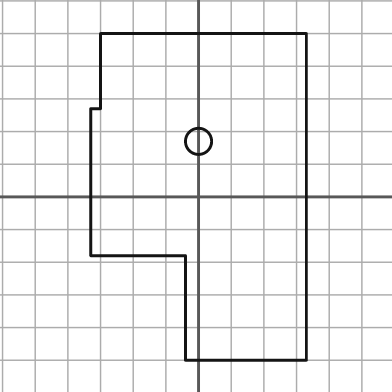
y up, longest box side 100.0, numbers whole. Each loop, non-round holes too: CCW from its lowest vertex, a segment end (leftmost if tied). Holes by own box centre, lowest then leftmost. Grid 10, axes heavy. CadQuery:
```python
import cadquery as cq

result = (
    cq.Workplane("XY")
    .moveTo(-4.0, -50.0)
    .lineTo(33.0, -50.0)
    .lineTo(33.0, 50.0)
    .lineTo(-30.0, 50.0)
    .lineTo(-30.0, 27.0)
    .lineTo(-33.0, 27.0)
    .lineTo(-33.0, -18.0)
    .lineTo(-4.0, -18.0)
    .close()
    .moveTo(0.0, 17.0)
    .circle(4.0)
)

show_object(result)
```